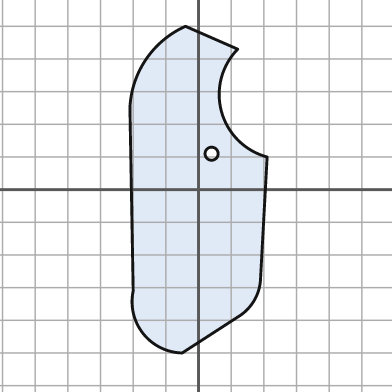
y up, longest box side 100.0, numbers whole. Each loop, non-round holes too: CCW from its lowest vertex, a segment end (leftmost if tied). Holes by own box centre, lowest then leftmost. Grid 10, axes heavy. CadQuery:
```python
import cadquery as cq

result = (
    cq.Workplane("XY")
    .moveTo(-5.0, -50.0)
    .lineTo(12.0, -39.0)
    .threePointArc((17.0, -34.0), (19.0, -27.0))
    .lineTo(21.0, 10.0)
    .threePointArc((7.0, 24.0), (12.0, 43.0))
    .lineTo(-4.0, 50.0)
    .threePointArc((-16.0, 40.0), (-21.0, 25.0))
    .lineTo(-20.0, -31.0)
    .threePointArc((-17.0, -44.0), (-5.0, -50.0))
    .close()
    .moveTo(4.0, 11.0)
    .circle(2.0)
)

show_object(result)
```